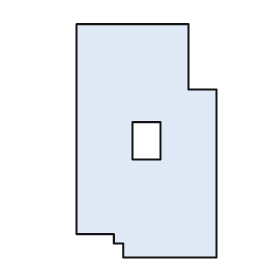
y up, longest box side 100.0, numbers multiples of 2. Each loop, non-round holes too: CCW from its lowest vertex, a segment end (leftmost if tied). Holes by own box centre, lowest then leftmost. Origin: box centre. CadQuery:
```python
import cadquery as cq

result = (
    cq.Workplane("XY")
    .moveTo(-10.0, -50.0)
    .lineTo(30.0, -50.0)
    .lineTo(30.0, 22.0)
    .lineTo(18.0, 22.0)
    .lineTo(18.0, 50.0)
    .lineTo(-30.0, 50.0)
    .lineTo(-30.0, -40.0)
    .lineTo(-14.0, -40.0)
    .lineTo(-14.0, -44.0)
    .lineTo(-10.0, -44.0)
    .close()
    .moveTo(-6.0, -8.0)
    .lineTo(6.0, -8.0)
    .lineTo(6.0, 8.0)
    .lineTo(-6.0, 8.0)
    .close()
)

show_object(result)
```